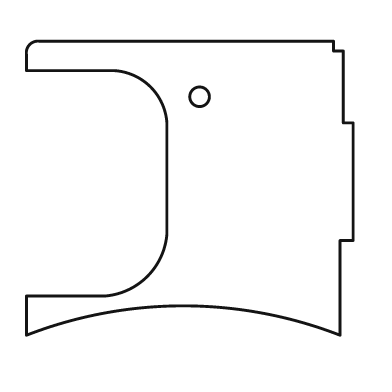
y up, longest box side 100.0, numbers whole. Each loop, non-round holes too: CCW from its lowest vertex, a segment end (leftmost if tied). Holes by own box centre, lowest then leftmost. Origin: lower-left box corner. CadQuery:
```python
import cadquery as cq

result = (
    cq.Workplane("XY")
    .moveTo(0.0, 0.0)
    .threePointArc((48.0, 9.0), (96.0, 0.0))
    .lineTo(96.0, 29.0)
    .lineTo(100.0, 29.0)
    .lineTo(100.0, 65.0)
    .lineTo(97.0, 65.0)
    .lineTo(97.0, 87.0)
    .lineTo(94.0, 87.0)
    .lineTo(94.0, 90.0)
    .lineTo(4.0, 90.0)
    .threePointArc((1.0, 89.0), (0.0, 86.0))
    .lineTo(0.0, 81.0)
    .lineTo(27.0, 81.0)
    .threePointArc((38.0, 76.0), (43.0, 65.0))
    .lineTo(43.0, 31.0)
    .threePointArc((37.0, 18.0), (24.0, 12.0))
    .lineTo(0.0, 12.0)
    .close()
    .moveTo(53.0, 73.0)
    .circle(3.0)
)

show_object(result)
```